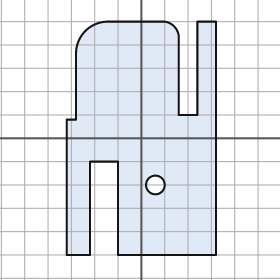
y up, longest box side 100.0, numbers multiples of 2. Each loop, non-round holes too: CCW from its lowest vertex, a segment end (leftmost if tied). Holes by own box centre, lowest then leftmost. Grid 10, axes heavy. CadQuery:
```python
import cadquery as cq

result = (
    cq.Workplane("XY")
    .moveTo(-32.0, -50.0)
    .lineTo(-22.0, -50.0)
    .lineTo(-22.0, -10.0)
    .lineTo(-10.0, -10.0)
    .lineTo(-10.0, -50.0)
    .lineTo(32.0, -50.0)
    .lineTo(32.0, 50.0)
    .lineTo(24.0, 50.0)
    .lineTo(24.0, 10.0)
    .lineTo(16.0, 10.0)
    .lineTo(16.0, 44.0)
    .threePointArc((14.0, 48.0), (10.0, 50.0))
    .lineTo(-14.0, 50.0)
    .threePointArc((-24.0, 46.0), (-28.0, 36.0))
    .lineTo(-28.0, 8.0)
    .lineTo(-32.0, 8.0)
    .close()
    .moveTo(6.0, -20.0)
    .circle(4.0)
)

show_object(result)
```